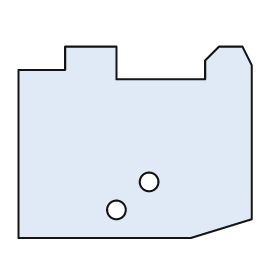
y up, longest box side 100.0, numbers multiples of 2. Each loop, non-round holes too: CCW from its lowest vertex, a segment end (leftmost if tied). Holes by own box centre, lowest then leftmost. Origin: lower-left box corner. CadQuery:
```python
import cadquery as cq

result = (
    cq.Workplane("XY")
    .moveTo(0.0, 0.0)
    .lineTo(74.0, 0.0)
    .lineTo(100.0, 8.0)
    .lineTo(100.0, 74.0)
    .lineTo(96.0, 82.0)
    .lineTo(86.0, 82.0)
    .lineTo(80.0, 76.0)
    .lineTo(80.0, 68.0)
    .lineTo(42.0, 68.0)
    .lineTo(42.0, 82.0)
    .lineTo(20.0, 82.0)
    .lineTo(20.0, 72.0)
    .lineTo(0.0, 72.0)
    .close()
    .moveTo(42.0, 12.0)
    .circle(4.0)
    .moveTo(56.0, 24.0)
    .circle(4.0)
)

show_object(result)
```